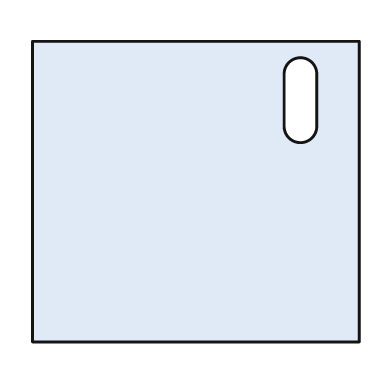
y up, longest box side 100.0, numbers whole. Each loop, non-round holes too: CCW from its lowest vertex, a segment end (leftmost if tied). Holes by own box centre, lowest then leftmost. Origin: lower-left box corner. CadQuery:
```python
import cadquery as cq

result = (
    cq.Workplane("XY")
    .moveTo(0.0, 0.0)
    .lineTo(100.0, 0.0)
    .lineTo(100.0, 92.0)
    .lineTo(0.0, 92.0)
    .close()
    .moveTo(77.0, 66.0)
    .threePointArc((82.0, 61.0), (87.0, 66.0))
    .lineTo(87.0, 82.0)
    .threePointArc((82.0, 87.0), (77.0, 82.0))
    .close()
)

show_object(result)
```